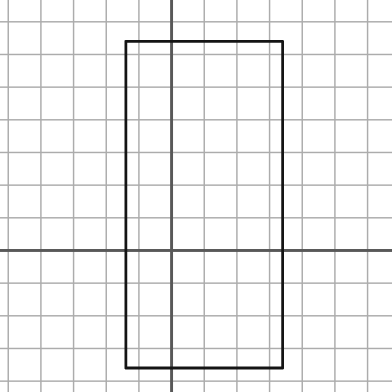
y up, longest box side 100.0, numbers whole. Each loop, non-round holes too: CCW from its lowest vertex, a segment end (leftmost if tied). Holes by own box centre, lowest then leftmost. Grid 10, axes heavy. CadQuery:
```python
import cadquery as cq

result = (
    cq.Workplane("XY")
    .moveTo(-14.0, -36.0)
    .lineTo(34.0, -36.0)
    .lineTo(34.0, 64.0)
    .lineTo(-14.0, 64.0)
    .close()
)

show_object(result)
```